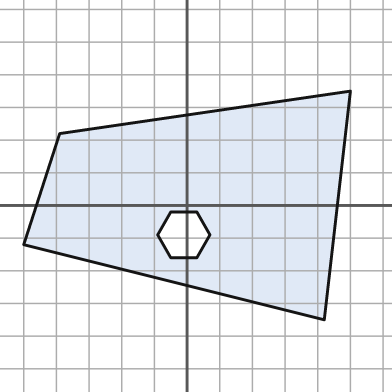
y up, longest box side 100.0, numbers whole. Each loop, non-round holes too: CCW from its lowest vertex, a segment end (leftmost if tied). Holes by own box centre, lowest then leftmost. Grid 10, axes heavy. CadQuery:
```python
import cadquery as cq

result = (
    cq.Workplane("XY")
    .moveTo(42.0, -35.0)
    .lineTo(50.0, 35.0)
    .lineTo(-39.0, 22.0)
    .lineTo(-50.0, -12.0)
    .close()
    .moveTo(-5.0, -16.0)
    .lineTo(3.0, -16.0)
    .lineTo(7.0, -9.0)
    .lineTo(3.0, -2.0)
    .lineTo(-5.0, -2.0)
    .lineTo(-9.0, -9.0)
    .close()
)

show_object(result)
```